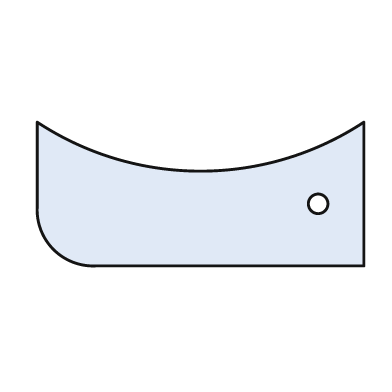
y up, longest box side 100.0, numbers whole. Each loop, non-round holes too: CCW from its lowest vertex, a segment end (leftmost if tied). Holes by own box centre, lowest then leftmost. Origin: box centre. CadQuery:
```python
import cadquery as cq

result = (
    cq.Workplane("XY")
    .moveTo(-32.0, -22.0)
    .lineTo(50.0, -22.0)
    .lineTo(50.0, 22.0)
    .threePointArc((0.0, 7.0), (-50.0, 22.0))
    .lineTo(-50.0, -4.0)
    .threePointArc((-45.0, -17.0), (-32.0, -22.0))
    .close()
    .moveTo(36.0, -3.0)
    .circle(3.0)
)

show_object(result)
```